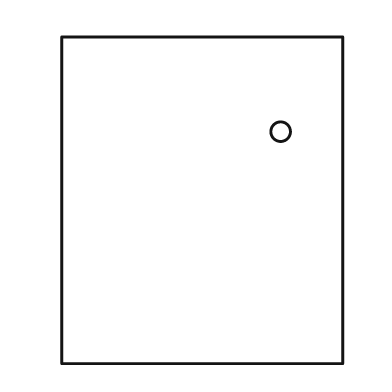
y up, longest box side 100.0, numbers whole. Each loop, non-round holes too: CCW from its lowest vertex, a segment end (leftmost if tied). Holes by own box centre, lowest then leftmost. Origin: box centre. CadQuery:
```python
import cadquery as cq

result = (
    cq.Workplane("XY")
    .moveTo(-43.0, -50.0)
    .lineTo(43.0, -50.0)
    .lineTo(43.0, 50.0)
    .lineTo(-43.0, 50.0)
    .close()
    .moveTo(24.0, 21.0)
    .circle(3.0)
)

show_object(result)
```